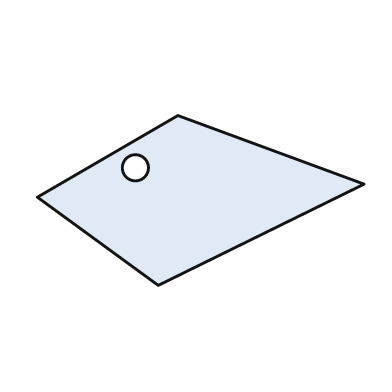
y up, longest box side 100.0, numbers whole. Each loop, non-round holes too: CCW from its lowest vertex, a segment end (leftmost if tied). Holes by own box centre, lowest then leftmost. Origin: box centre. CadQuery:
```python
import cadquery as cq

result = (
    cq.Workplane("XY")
    .moveTo(-13.0, -26.0)
    .lineTo(50.0, 5.0)
    .lineTo(-7.0, 26.0)
    .lineTo(-50.0, 1.0)
    .close()
    .moveTo(-20.0, 10.0)
    .circle(4.0)
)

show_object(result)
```